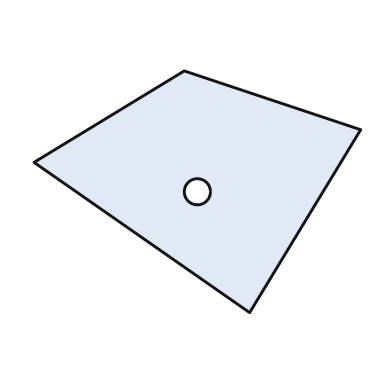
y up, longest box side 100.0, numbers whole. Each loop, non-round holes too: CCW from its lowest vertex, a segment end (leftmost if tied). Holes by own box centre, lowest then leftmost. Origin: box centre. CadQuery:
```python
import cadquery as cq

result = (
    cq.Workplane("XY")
    .moveTo(16.0, -37.0)
    .lineTo(50.0, 19.0)
    .lineTo(-4.0, 37.0)
    .lineTo(-50.0, 9.0)
    .close()
    .moveTo(0.0, 0.0)
    .circle(4.0)
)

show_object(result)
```